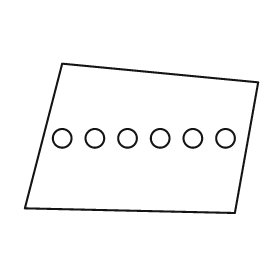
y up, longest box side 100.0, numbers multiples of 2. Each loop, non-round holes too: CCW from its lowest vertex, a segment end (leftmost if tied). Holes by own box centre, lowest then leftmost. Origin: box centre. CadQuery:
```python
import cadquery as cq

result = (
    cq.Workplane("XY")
    .moveTo(40.0, -32.0)
    .lineTo(50.0, 24.0)
    .lineTo(-34.0, 32.0)
    .lineTo(-50.0, -30.0)
    .close()
    .moveTo(-34.0, 0.0)
    .circle(4.0)
    .moveTo(-20.0, 0.0)
    .circle(4.0)
    .moveTo(-6.0, 0.0)
    .circle(4.0)
    .moveTo(8.0, 0.0)
    .circle(4.0)
    .moveTo(22.0, 0.0)
    .circle(4.0)
    .moveTo(36.0, 0.0)
    .circle(4.0)
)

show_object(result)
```